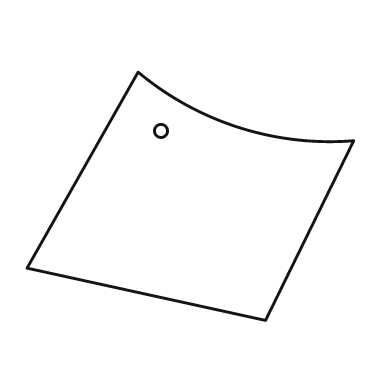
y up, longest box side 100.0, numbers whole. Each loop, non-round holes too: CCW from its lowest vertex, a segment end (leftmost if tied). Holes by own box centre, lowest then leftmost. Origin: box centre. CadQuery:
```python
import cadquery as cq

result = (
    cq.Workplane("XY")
    .moveTo(23.0, -38.0)
    .lineTo(50.0, 17.0)
    .threePointArc((15.0, 21.0), (-16.0, 38.0))
    .lineTo(-50.0, -22.0)
    .close()
    .moveTo(-9.0, 20.0)
    .circle(2.0)
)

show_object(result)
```